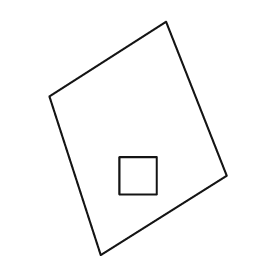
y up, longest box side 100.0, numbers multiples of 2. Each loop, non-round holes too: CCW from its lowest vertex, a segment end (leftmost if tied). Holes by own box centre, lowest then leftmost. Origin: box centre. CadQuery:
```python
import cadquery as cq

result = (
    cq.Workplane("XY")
    .moveTo(-16.0, -50.0)
    .lineTo(38.0, -16.0)
    .lineTo(12.0, 50.0)
    .lineTo(-38.0, 18.0)
    .close()
    .moveTo(-8.0, -24.0)
    .lineTo(8.0, -24.0)
    .lineTo(8.0, -8.0)
    .lineTo(-8.0, -8.0)
    .close()
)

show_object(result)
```